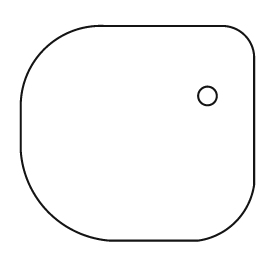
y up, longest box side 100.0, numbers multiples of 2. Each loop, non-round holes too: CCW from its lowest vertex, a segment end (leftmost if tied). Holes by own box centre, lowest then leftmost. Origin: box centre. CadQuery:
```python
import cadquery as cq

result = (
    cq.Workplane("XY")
    .moveTo(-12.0, -46.0)
    .lineTo(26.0, -46.0)
    .threePointArc((42.0, -38.0), (50.0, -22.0))
    .lineTo(50.0, 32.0)
    .threePointArc((46.0, 42.0), (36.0, 46.0))
    .lineTo(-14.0, 46.0)
    .threePointArc((-40.0, 36.0), (-50.0, 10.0))
    .lineTo(-50.0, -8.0)
    .threePointArc((-38.0, -34.0), (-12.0, -46.0))
    .close()
    .moveTo(30.0, 16.0)
    .circle(4.0)
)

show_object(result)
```